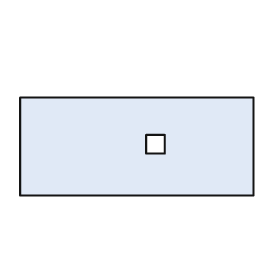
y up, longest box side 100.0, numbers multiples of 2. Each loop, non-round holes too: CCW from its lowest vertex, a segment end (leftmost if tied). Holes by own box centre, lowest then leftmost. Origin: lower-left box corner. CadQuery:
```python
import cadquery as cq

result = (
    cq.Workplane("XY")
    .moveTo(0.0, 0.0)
    .lineTo(100.0, 0.0)
    .lineTo(100.0, 42.0)
    .lineTo(0.0, 42.0)
    .close()
    .moveTo(54.0, 18.0)
    .lineTo(62.0, 18.0)
    .lineTo(62.0, 26.0)
    .lineTo(54.0, 26.0)
    .close()
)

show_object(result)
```